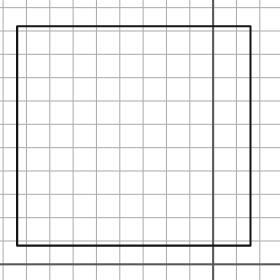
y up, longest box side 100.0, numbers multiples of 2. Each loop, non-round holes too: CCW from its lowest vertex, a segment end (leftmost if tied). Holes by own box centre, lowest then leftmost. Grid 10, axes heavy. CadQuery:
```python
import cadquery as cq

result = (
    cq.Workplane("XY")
    .moveTo(-84.0, 8.0)
    .lineTo(16.0, 8.0)
    .lineTo(16.0, 102.0)
    .lineTo(-84.0, 102.0)
    .close()
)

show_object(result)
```